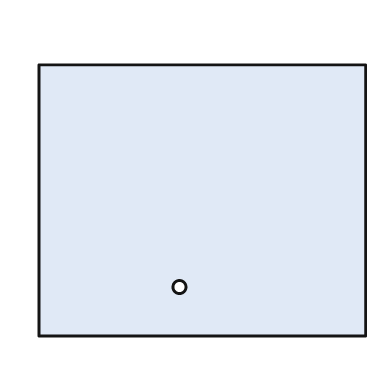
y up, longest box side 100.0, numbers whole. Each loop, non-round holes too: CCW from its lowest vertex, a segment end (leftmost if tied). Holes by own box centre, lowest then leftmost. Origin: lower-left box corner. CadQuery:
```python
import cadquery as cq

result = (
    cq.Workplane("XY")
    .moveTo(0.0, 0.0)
    .lineTo(100.0, 0.0)
    .lineTo(100.0, 83.0)
    .lineTo(0.0, 83.0)
    .close()
    .moveTo(43.0, 15.0)
    .circle(2.0)
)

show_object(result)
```